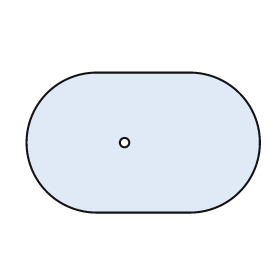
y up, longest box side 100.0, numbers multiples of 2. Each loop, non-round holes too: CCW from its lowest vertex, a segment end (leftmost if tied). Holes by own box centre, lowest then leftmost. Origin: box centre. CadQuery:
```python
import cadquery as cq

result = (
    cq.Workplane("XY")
    .moveTo(-20.0, -30.0)
    .lineTo(20.0, -30.0)
    .threePointArc((50.0, 0.0), (20.0, 30.0))
    .lineTo(-20.0, 30.0)
    .threePointArc((-50.0, 0.0), (-20.0, -30.0))
    .close()
    .moveTo(-8.0, 0.0)
    .circle(2.0)
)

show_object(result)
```